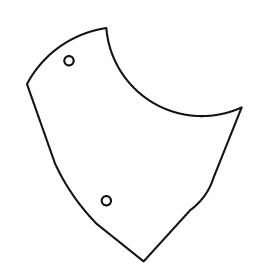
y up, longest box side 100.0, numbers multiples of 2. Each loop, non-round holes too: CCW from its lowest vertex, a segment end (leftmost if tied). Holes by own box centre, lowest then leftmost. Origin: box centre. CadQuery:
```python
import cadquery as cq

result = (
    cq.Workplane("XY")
    .moveTo(4.0, -50.0)
    .lineTo(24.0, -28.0)
    .threePointArc((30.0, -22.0), (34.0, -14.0))
    .lineTo(46.0, 16.0)
    .threePointArc((8.0, 18.0), (-12.0, 50.0))
    .threePointArc((-32.0, 42.0), (-46.0, 26.0))
    .lineTo(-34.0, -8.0)
    .threePointArc((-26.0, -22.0), (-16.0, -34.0))
    .close()
    .moveTo(-12.0, -24.0)
    .circle(2.0)
    .moveTo(-28.0, 36.0)
    .circle(2.0)
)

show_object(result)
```